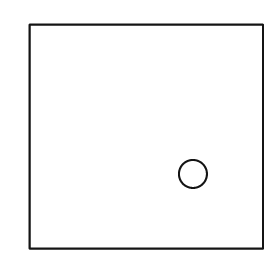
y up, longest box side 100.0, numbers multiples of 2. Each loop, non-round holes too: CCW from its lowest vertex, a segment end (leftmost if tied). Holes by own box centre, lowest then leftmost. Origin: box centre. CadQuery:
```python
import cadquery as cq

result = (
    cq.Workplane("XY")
    .moveTo(-50.0, -48.0)
    .lineTo(50.0, -48.0)
    .lineTo(50.0, 48.0)
    .lineTo(-50.0, 48.0)
    .close()
    .moveTo(20.0, -16.0)
    .circle(6.0)
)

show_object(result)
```